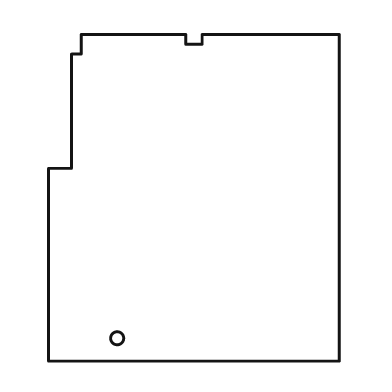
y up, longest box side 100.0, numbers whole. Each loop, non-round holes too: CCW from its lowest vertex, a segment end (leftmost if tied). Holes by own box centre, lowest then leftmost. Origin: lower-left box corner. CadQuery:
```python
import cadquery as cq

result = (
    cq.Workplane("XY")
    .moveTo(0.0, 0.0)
    .lineTo(89.0, 0.0)
    .lineTo(89.0, 100.0)
    .lineTo(47.0, 100.0)
    .lineTo(47.0, 97.0)
    .lineTo(42.0, 97.0)
    .lineTo(42.0, 100.0)
    .lineTo(10.0, 100.0)
    .lineTo(10.0, 94.0)
    .lineTo(7.0, 94.0)
    .lineTo(7.0, 59.0)
    .lineTo(0.0, 59.0)
    .close()
    .moveTo(21.0, 7.0)
    .circle(2.0)
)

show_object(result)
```